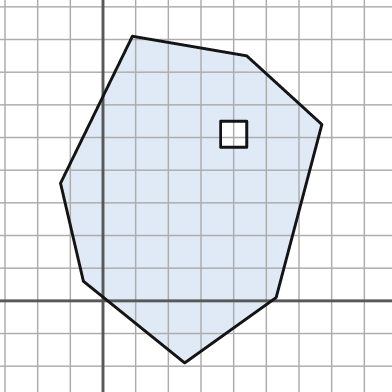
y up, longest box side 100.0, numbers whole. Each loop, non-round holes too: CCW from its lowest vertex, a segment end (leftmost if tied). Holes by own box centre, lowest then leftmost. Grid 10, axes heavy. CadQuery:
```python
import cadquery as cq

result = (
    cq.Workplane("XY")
    .moveTo(25.0, -19.0)
    .lineTo(53.0, 1.0)
    .lineTo(67.0, 54.0)
    .lineTo(44.0, 75.0)
    .lineTo(9.0, 81.0)
    .lineTo(-13.0, 36.0)
    .lineTo(-6.0, 6.0)
    .close()
    .moveTo(36.0, 47.0)
    .lineTo(44.0, 47.0)
    .lineTo(44.0, 55.0)
    .lineTo(36.0, 55.0)
    .close()
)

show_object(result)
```